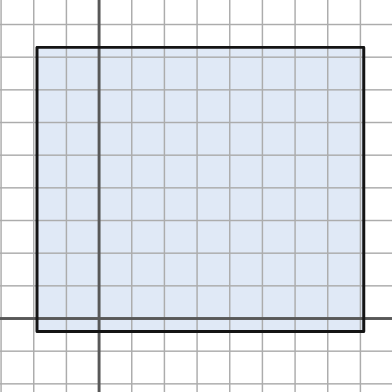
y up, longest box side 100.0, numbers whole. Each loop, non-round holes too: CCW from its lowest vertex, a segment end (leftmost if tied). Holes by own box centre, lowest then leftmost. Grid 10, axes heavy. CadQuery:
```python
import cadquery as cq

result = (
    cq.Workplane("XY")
    .moveTo(-19.0, -4.0)
    .lineTo(81.0, -4.0)
    .lineTo(81.0, 83.0)
    .lineTo(-19.0, 83.0)
    .close()
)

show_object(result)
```